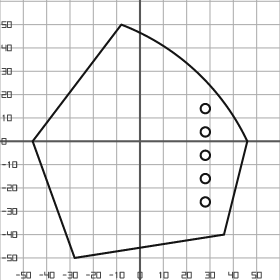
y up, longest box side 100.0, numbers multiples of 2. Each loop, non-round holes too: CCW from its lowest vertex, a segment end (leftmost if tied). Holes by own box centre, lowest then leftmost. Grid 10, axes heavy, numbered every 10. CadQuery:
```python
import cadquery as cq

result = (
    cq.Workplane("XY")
    .moveTo(-28.0, -50.0)
    .lineTo(36.0, -40.0)
    .lineTo(46.0, 0.0)
    .threePointArc((24.0, 30.0), (-8.0, 50.0))
    .lineTo(-46.0, 0.0)
    .close()
    .moveTo(28.0, -26.0)
    .circle(2.0)
    .moveTo(28.0, -16.0)
    .circle(2.0)
    .moveTo(28.0, -6.0)
    .circle(2.0)
    .moveTo(28.0, 4.0)
    .circle(2.0)
    .moveTo(28.0, 14.0)
    .circle(2.0)
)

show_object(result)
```